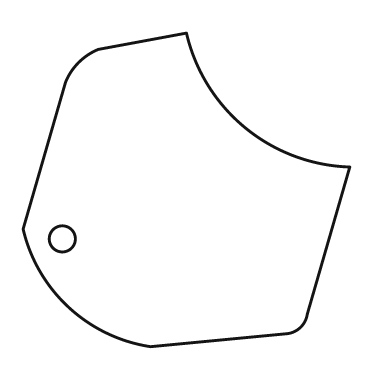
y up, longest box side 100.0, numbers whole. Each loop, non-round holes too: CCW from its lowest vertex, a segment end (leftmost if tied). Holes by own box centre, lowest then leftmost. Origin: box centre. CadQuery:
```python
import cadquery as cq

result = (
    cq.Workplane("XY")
    .moveTo(-11.0, -48.0)
    .lineTo(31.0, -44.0)
    .threePointArc((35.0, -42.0), (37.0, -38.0))
    .lineTo(50.0, 7.0)
    .threePointArc((18.0, 19.0), (0.0, 48.0))
    .lineTo(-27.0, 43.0)
    .threePointArc((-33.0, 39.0), (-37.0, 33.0))
    .lineTo(-50.0, -12.0)
    .threePointArc((-36.0, -36.0), (-11.0, -48.0))
    .close()
    .moveTo(-38.0, -15.0)
    .circle(4.0)
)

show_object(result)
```